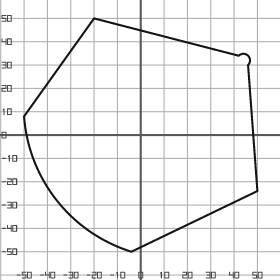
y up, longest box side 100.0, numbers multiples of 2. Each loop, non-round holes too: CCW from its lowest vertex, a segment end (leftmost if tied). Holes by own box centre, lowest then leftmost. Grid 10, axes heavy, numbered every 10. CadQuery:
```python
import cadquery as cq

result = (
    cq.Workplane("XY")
    .moveTo(-4.0, -50.0)
    .lineTo(50.0, -24.0)
    .lineTo(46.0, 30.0)
    .threePointArc((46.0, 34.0), (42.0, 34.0))
    .lineTo(-20.0, 50.0)
    .lineTo(-50.0, 8.0)
    .threePointArc((-36.0, -28.0), (-4.0, -50.0))
    .close()
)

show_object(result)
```